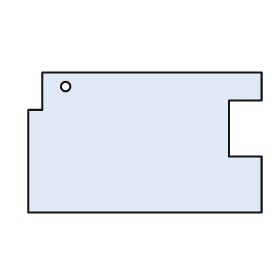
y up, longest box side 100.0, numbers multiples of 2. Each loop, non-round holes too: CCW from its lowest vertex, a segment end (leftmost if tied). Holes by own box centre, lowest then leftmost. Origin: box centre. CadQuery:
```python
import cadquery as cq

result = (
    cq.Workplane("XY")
    .moveTo(-50.0, -30.0)
    .lineTo(50.0, -30.0)
    .lineTo(50.0, -6.0)
    .lineTo(36.0, -6.0)
    .lineTo(36.0, 18.0)
    .lineTo(50.0, 18.0)
    .lineTo(50.0, 30.0)
    .lineTo(-44.0, 30.0)
    .lineTo(-44.0, 14.0)
    .lineTo(-50.0, 14.0)
    .close()
    .moveTo(-34.0, 24.0)
    .circle(2.0)
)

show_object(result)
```